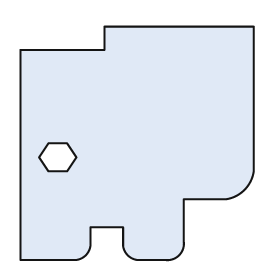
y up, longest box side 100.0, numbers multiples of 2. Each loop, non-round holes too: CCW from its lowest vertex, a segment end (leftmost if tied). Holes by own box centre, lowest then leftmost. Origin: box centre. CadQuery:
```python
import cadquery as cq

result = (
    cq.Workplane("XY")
    .moveTo(-50.0, -50.0)
    .lineTo(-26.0, -50.0)
    .threePointArc((-22.0, -48.0), (-20.0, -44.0))
    .lineTo(-20.0, -36.0)
    .lineTo(-6.0, -36.0)
    .lineTo(-6.0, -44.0)
    .threePointArc((-4.0, -48.0), (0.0, -50.0))
    .lineTo(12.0, -50.0)
    .threePointArc((18.0, -48.0), (20.0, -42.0))
    .lineTo(20.0, -24.0)
    .lineTo(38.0, -24.0)
    .threePointArc((46.0, -20.0), (50.0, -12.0))
    .lineTo(50.0, 50.0)
    .lineTo(-14.0, 50.0)
    .lineTo(-14.0, 40.0)
    .lineTo(-50.0, 40.0)
    .close()
    .moveTo(-38.0, -12.0)
    .lineTo(-30.0, -12.0)
    .lineTo(-26.0, -6.0)
    .lineTo(-30.0, 0.0)
    .lineTo(-38.0, 0.0)
    .lineTo(-42.0, -6.0)
    .close()
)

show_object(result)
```